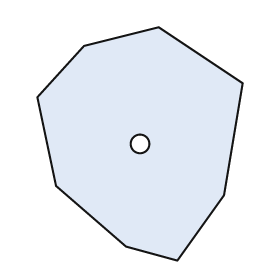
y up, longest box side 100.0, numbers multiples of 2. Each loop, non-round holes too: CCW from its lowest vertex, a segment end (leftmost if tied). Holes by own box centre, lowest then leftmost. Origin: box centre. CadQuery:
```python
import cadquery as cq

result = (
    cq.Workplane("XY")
    .moveTo(16.0, -50.0)
    .lineTo(36.0, -22.0)
    .lineTo(44.0, 26.0)
    .lineTo(8.0, 50.0)
    .lineTo(-24.0, 42.0)
    .lineTo(-44.0, 20.0)
    .lineTo(-36.0, -18.0)
    .lineTo(-6.0, -44.0)
    .close()
    .moveTo(0.0, 0.0)
    .circle(4.0)
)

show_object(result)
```